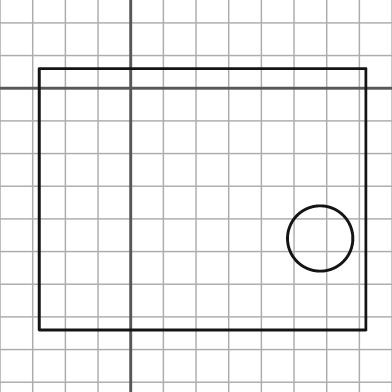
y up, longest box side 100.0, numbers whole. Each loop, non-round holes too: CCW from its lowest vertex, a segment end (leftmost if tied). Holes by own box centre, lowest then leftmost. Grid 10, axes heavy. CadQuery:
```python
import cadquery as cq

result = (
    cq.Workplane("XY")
    .moveTo(-28.0, -74.0)
    .lineTo(72.0, -74.0)
    .lineTo(72.0, 6.0)
    .lineTo(-28.0, 6.0)
    .close()
    .moveTo(58.0, -46.0)
    .circle(10.0)
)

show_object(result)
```